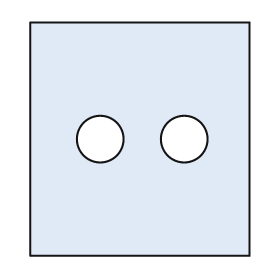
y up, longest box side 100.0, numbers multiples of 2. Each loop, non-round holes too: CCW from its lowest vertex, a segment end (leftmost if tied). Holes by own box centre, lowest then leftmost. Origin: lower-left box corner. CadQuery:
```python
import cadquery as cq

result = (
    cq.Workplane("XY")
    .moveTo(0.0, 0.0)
    .lineTo(94.0, 0.0)
    .lineTo(94.0, 100.0)
    .lineTo(0.0, 100.0)
    .close()
    .moveTo(30.0, 50.0)
    .circle(10.0)
    .moveTo(66.0, 50.0)
    .circle(10.0)
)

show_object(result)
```